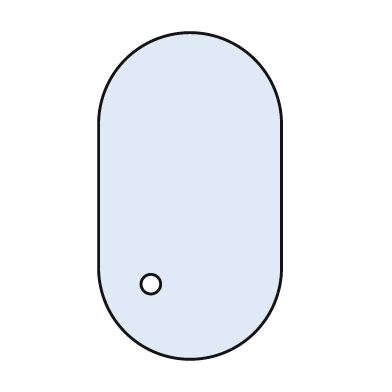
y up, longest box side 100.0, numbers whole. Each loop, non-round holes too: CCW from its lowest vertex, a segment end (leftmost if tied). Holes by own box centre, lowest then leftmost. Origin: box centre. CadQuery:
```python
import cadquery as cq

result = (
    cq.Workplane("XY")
    .moveTo(-28.0, -22.0)
    .threePointArc((0.0, -50.0), (28.0, -22.0))
    .lineTo(28.0, 22.0)
    .threePointArc((0.0, 50.0), (-28.0, 22.0))
    .close()
    .moveTo(-12.0, -27.0)
    .circle(3.0)
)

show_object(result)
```